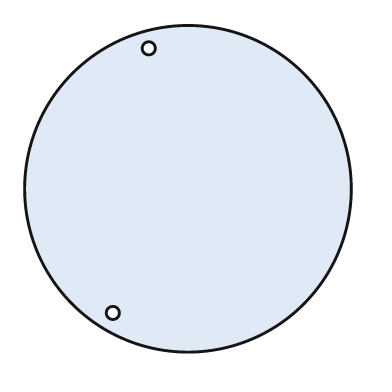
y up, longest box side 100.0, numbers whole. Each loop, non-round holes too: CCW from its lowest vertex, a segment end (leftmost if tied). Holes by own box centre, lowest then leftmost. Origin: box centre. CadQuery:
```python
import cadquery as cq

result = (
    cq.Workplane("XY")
    .moveTo(0.0, 0.0)
    .circle(50.0)
    .moveTo(-23.0, -38.0)
    .circle(2.0)
    .moveTo(-12.0, 43.0)
    .circle(2.0)
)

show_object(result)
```